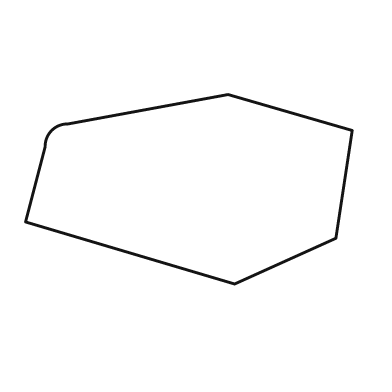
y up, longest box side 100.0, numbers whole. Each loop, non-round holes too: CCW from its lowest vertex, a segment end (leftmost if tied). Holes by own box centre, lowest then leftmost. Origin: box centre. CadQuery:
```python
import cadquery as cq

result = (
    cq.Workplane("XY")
    .moveTo(14.0, -29.0)
    .lineTo(45.0, -15.0)
    .lineTo(50.0, 18.0)
    .lineTo(12.0, 29.0)
    .lineTo(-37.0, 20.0)
    .threePointArc((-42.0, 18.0), (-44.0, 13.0))
    .lineTo(-50.0, -10.0)
    .close()
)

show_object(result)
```